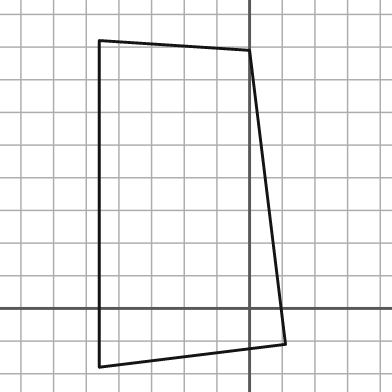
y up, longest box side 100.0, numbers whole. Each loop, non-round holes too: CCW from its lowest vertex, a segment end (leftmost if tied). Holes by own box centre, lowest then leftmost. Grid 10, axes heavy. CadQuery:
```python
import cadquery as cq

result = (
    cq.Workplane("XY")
    .moveTo(-46.0, -18.0)
    .lineTo(11.0, -11.0)
    .lineTo(0.0, 79.0)
    .lineTo(-46.0, 82.0)
    .close()
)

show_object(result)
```